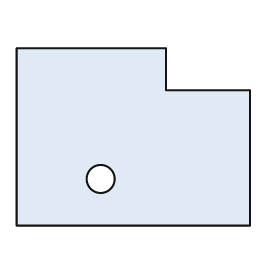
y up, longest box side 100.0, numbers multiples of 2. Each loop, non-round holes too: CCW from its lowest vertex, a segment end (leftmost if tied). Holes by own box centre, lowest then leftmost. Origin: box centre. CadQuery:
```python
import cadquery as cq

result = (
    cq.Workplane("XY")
    .moveTo(-50.0, -38.0)
    .lineTo(50.0, -38.0)
    .lineTo(50.0, 20.0)
    .lineTo(14.0, 20.0)
    .lineTo(14.0, 38.0)
    .lineTo(-50.0, 38.0)
    .close()
    .moveTo(-14.0, -18.0)
    .circle(6.0)
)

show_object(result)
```